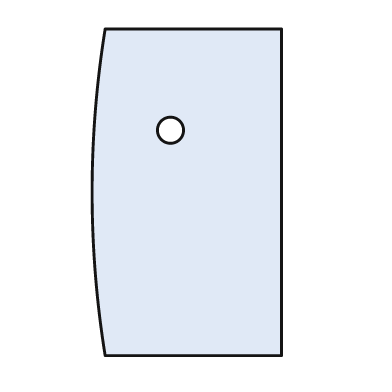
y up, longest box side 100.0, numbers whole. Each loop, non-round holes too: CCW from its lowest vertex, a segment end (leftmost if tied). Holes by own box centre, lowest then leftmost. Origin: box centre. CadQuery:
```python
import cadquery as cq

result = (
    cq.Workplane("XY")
    .moveTo(-25.0, -50.0)
    .lineTo(29.0, -50.0)
    .lineTo(29.0, 50.0)
    .lineTo(-25.0, 50.0)
    .threePointArc((-29.0, 0.0), (-25.0, -50.0))
    .close()
    .moveTo(-5.0, 19.0)
    .circle(4.0)
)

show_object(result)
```